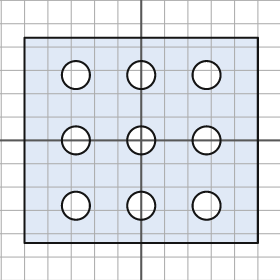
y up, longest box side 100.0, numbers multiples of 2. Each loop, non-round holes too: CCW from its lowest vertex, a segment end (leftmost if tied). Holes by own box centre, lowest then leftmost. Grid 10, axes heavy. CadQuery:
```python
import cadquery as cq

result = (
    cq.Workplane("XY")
    .moveTo(-50.0, -44.0)
    .lineTo(50.0, -44.0)
    .lineTo(50.0, 44.0)
    .lineTo(-50.0, 44.0)
    .close()
    .moveTo(-28.0, -28.0)
    .circle(6.0)
    .moveTo(0.0, -28.0)
    .circle(6.0)
    .moveTo(28.0, -28.0)
    .circle(6.0)
    .moveTo(-28.0, 0.0)
    .circle(6.0)
    .moveTo(0.0, 0.0)
    .circle(6.0)
    .moveTo(28.0, 0.0)
    .circle(6.0)
    .moveTo(-28.0, 28.0)
    .circle(6.0)
    .moveTo(0.0, 28.0)
    .circle(6.0)
    .moveTo(28.0, 28.0)
    .circle(6.0)
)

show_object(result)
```